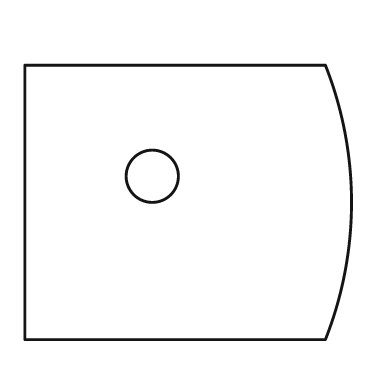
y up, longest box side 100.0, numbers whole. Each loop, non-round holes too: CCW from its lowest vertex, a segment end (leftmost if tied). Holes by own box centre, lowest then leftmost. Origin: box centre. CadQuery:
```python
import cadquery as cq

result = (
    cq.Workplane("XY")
    .moveTo(-50.0, -42.0)
    .lineTo(42.0, -42.0)
    .threePointArc((50.0, 0.0), (42.0, 42.0))
    .lineTo(-50.0, 42.0)
    .close()
    .moveTo(-11.0, 8.0)
    .circle(8.0)
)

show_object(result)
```